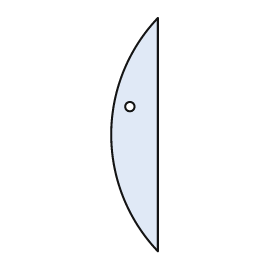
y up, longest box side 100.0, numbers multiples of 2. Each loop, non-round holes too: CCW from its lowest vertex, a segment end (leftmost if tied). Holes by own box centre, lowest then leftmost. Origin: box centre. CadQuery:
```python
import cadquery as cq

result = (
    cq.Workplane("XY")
    .moveTo(10.0, -50.0)
    .lineTo(10.0, 50.0)
    .threePointArc((-10.0, 0.0), (10.0, -50.0))
    .close()
    .moveTo(-2.0, 12.0)
    .circle(2.0)
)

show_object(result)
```